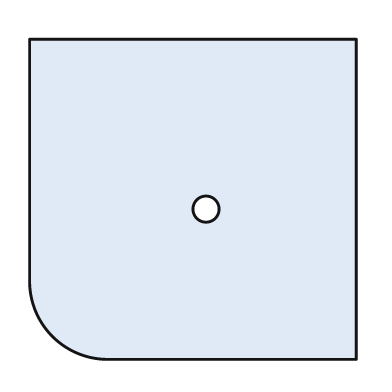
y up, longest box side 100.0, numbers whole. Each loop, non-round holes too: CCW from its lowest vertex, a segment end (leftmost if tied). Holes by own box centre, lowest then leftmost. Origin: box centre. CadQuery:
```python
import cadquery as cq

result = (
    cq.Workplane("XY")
    .moveTo(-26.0, -49.0)
    .lineTo(50.0, -49.0)
    .lineTo(50.0, 49.0)
    .lineTo(-50.0, 49.0)
    .lineTo(-50.0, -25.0)
    .threePointArc((-43.0, -42.0), (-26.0, -49.0))
    .close()
    .moveTo(4.0, -3.0)
    .circle(4.0)
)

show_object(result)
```